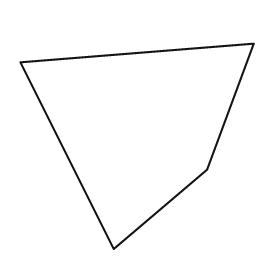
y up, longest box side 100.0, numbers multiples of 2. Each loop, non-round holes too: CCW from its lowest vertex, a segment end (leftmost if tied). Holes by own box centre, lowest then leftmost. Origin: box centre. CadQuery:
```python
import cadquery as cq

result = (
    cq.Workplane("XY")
    .moveTo(-10.0, -44.0)
    .lineTo(30.0, -10.0)
    .lineTo(50.0, 44.0)
    .lineTo(-50.0, 36.0)
    .close()
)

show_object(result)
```